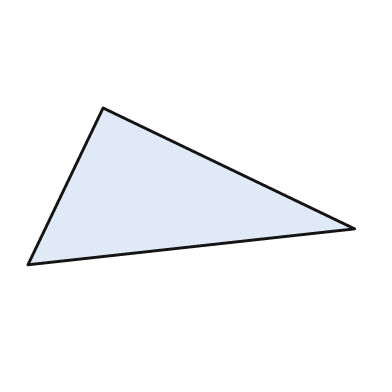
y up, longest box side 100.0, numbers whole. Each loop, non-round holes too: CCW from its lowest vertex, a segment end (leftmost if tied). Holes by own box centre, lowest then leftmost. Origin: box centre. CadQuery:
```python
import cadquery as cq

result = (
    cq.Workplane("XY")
    .moveTo(-50.0, -24.0)
    .lineTo(50.0, -13.0)
    .lineTo(-27.0, 24.0)
    .close()
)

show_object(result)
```